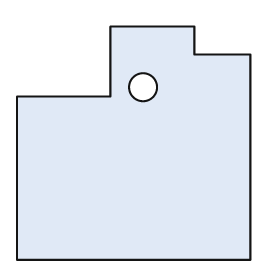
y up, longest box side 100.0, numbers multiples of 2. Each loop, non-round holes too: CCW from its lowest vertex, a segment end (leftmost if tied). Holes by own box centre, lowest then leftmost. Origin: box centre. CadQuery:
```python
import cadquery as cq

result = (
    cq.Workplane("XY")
    .moveTo(-50.0, -50.0)
    .lineTo(50.0, -50.0)
    .lineTo(50.0, 38.0)
    .lineTo(26.0, 38.0)
    .lineTo(26.0, 50.0)
    .lineTo(-10.0, 50.0)
    .lineTo(-10.0, 20.0)
    .lineTo(-50.0, 20.0)
    .close()
    .moveTo(4.0, 24.0)
    .circle(6.0)
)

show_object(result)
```